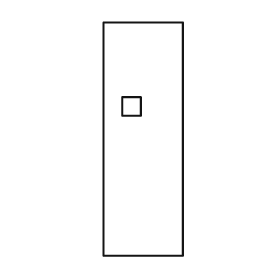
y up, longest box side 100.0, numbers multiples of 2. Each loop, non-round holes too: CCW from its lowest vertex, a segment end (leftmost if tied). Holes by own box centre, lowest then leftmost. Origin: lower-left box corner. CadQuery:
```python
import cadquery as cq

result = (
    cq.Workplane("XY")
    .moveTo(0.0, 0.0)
    .lineTo(34.0, 0.0)
    .lineTo(34.0, 100.0)
    .lineTo(0.0, 100.0)
    .close()
    .moveTo(8.0, 60.0)
    .lineTo(16.0, 60.0)
    .lineTo(16.0, 68.0)
    .lineTo(8.0, 68.0)
    .close()
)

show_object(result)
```